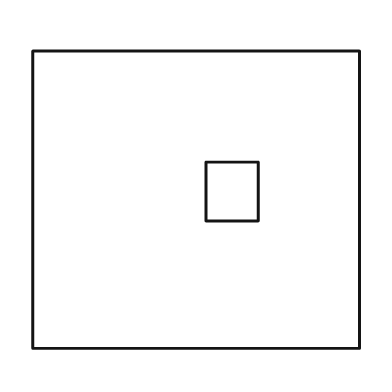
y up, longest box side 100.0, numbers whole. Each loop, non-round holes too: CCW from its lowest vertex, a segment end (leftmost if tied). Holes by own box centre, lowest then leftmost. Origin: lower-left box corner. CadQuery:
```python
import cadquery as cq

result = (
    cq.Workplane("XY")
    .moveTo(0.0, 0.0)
    .lineTo(100.0, 0.0)
    .lineTo(100.0, 91.0)
    .lineTo(0.0, 91.0)
    .close()
    .moveTo(53.0, 39.0)
    .lineTo(69.0, 39.0)
    .lineTo(69.0, 57.0)
    .lineTo(53.0, 57.0)
    .close()
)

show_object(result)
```